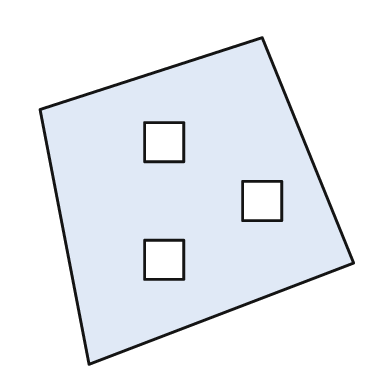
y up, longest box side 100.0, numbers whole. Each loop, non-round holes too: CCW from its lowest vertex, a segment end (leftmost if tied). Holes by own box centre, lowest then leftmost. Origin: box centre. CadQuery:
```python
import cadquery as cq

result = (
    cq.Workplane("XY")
    .moveTo(-33.0, -50.0)
    .lineTo(48.0, -19.0)
    .lineTo(20.0, 50.0)
    .lineTo(-48.0, 28.0)
    .close()
    .moveTo(-16.0, -24.0)
    .lineTo(-4.0, -24.0)
    .lineTo(-4.0, -12.0)
    .lineTo(-16.0, -12.0)
    .close()
    .moveTo(14.0, -6.0)
    .lineTo(26.0, -6.0)
    .lineTo(26.0, 6.0)
    .lineTo(14.0, 6.0)
    .close()
    .moveTo(-16.0, 12.0)
    .lineTo(-4.0, 12.0)
    .lineTo(-4.0, 24.0)
    .lineTo(-16.0, 24.0)
    .close()
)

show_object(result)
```